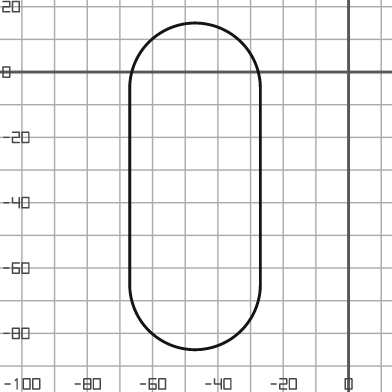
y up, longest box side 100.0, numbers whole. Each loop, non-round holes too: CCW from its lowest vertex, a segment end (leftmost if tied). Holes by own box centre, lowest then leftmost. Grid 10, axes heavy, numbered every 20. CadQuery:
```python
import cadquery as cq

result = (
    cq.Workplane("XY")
    .moveTo(-67.0, -65.0)
    .threePointArc((-47.0, -85.0), (-27.0, -65.0))
    .lineTo(-27.0, -5.0)
    .threePointArc((-47.0, 15.0), (-67.0, -5.0))
    .close()
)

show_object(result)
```